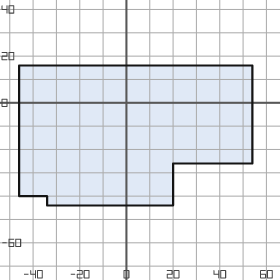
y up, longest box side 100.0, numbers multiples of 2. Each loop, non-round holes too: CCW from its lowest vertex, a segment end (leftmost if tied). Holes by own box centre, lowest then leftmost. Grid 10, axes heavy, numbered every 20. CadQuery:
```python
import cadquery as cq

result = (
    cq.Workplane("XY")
    .moveTo(-34.0, -44.0)
    .lineTo(20.0, -44.0)
    .lineTo(20.0, -26.0)
    .lineTo(54.0, -26.0)
    .lineTo(54.0, 16.0)
    .lineTo(-46.0, 16.0)
    .lineTo(-46.0, -40.0)
    .lineTo(-34.0, -40.0)
    .close()
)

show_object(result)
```